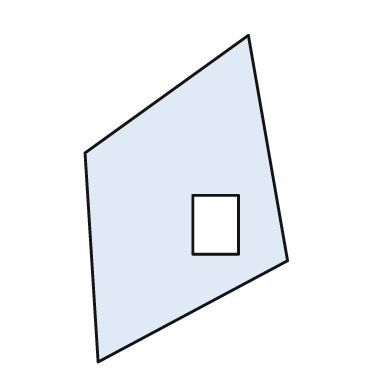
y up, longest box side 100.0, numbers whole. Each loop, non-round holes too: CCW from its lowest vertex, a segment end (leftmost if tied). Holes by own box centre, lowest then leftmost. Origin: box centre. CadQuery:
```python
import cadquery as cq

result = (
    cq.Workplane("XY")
    .moveTo(-27.0, -50.0)
    .lineTo(31.0, -19.0)
    .lineTo(19.0, 50.0)
    .lineTo(-31.0, 14.0)
    .close()
    .moveTo(2.0, -17.0)
    .lineTo(16.0, -17.0)
    .lineTo(16.0, 1.0)
    .lineTo(2.0, 1.0)
    .close()
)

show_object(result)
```